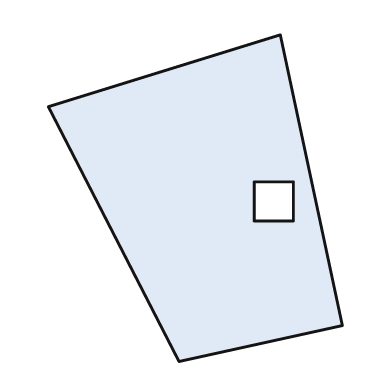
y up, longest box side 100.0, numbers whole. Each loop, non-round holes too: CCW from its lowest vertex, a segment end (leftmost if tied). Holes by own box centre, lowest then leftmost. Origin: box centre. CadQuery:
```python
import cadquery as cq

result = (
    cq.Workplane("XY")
    .moveTo(-5.0, -50.0)
    .lineTo(45.0, -39.0)
    .lineTo(26.0, 50.0)
    .lineTo(-45.0, 28.0)
    .close()
    .moveTo(18.0, -7.0)
    .lineTo(30.0, -7.0)
    .lineTo(30.0, 5.0)
    .lineTo(18.0, 5.0)
    .close()
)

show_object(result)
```